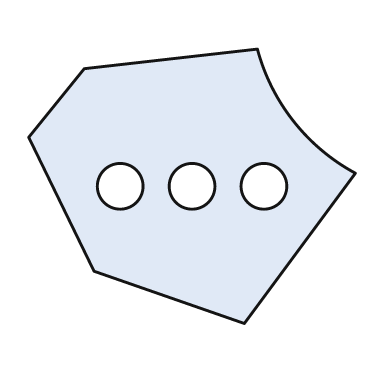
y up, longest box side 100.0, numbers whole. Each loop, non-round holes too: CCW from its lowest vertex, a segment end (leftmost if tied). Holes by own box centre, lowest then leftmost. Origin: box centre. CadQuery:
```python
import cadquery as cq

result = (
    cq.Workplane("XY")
    .moveTo(16.0, -42.0)
    .lineTo(50.0, 4.0)
    .threePointArc((31.0, 20.0), (20.0, 42.0))
    .lineTo(-33.0, 36.0)
    .lineTo(-50.0, 15.0)
    .lineTo(-30.0, -26.0)
    .close()
    .moveTo(-22.0, 0.0)
    .circle(7.0)
    .moveTo(0.0, 0.0)
    .circle(7.0)
    .moveTo(22.0, 0.0)
    .circle(7.0)
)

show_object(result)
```